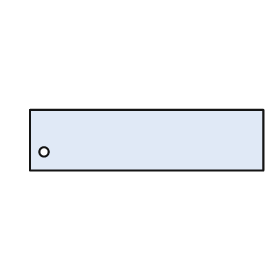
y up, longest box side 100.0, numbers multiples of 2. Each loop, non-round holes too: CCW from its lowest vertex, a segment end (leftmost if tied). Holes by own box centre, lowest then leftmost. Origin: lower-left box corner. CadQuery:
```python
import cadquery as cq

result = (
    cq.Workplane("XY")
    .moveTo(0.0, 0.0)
    .lineTo(100.0, 0.0)
    .lineTo(100.0, 26.0)
    .lineTo(0.0, 26.0)
    .close()
    .moveTo(6.0, 8.0)
    .circle(2.0)
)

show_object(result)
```